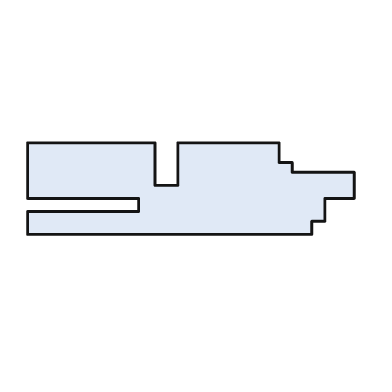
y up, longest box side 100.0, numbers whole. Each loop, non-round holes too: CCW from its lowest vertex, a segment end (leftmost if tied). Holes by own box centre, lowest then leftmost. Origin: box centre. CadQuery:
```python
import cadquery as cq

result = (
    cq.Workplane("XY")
    .moveTo(-50.0, -14.0)
    .lineTo(37.0, -14.0)
    .lineTo(37.0, -10.0)
    .lineTo(41.0, -10.0)
    .lineTo(41.0, -3.0)
    .lineTo(50.0, -3.0)
    .lineTo(50.0, 5.0)
    .lineTo(31.0, 5.0)
    .lineTo(31.0, 8.0)
    .lineTo(27.0, 8.0)
    .lineTo(27.0, 14.0)
    .lineTo(-4.0, 14.0)
    .lineTo(-4.0, 1.0)
    .lineTo(-11.0, 1.0)
    .lineTo(-11.0, 14.0)
    .lineTo(-50.0, 14.0)
    .lineTo(-50.0, -3.0)
    .lineTo(-16.0, -3.0)
    .lineTo(-16.0, -7.0)
    .lineTo(-50.0, -7.0)
    .close()
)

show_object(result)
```